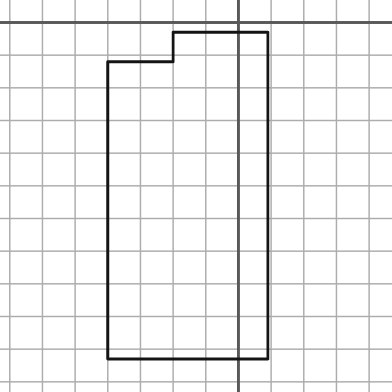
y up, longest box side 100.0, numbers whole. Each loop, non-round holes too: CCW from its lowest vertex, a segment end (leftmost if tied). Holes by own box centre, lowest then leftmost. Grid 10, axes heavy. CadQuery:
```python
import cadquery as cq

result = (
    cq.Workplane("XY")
    .moveTo(-40.0, -103.0)
    .lineTo(9.0, -103.0)
    .lineTo(9.0, -3.0)
    .lineTo(-20.0, -3.0)
    .lineTo(-20.0, -12.0)
    .lineTo(-40.0, -12.0)
    .close()
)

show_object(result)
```